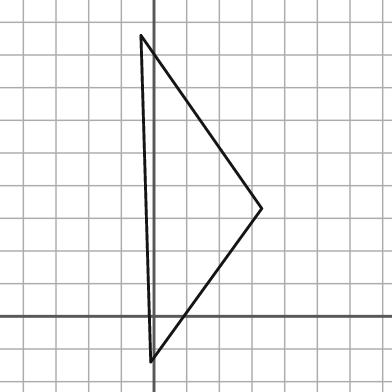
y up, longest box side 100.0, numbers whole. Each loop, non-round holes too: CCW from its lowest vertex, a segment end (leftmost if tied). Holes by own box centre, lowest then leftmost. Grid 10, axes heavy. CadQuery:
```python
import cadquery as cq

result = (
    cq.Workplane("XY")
    .moveTo(-1.0, -14.0)
    .lineTo(33.0, 33.0)
    .lineTo(-4.0, 86.0)
    .close()
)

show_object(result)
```